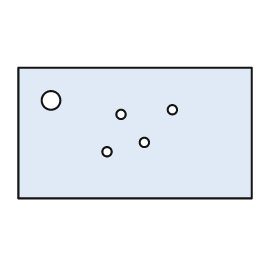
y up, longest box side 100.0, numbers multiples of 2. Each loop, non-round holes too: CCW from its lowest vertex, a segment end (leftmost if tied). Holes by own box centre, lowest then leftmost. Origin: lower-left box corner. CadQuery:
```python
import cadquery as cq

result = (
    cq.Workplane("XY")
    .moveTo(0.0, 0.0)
    .lineTo(100.0, 0.0)
    .lineTo(100.0, 56.0)
    .lineTo(0.0, 56.0)
    .close()
    .moveTo(38.0, 20.0)
    .circle(2.0)
    .moveTo(54.0, 24.0)
    .circle(2.0)
    .moveTo(44.0, 36.0)
    .circle(2.0)
    .moveTo(66.0, 38.0)
    .circle(2.0)
    .moveTo(14.0, 42.0)
    .circle(4.0)
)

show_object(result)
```